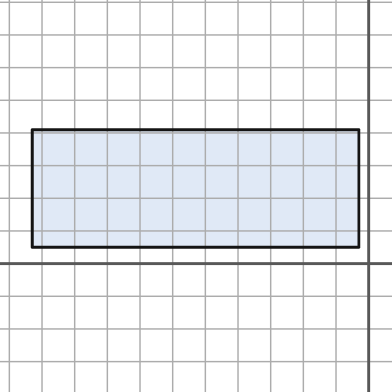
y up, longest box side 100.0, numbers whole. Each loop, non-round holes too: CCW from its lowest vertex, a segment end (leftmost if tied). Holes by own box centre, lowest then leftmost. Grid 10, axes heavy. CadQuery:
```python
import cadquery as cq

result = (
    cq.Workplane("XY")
    .moveTo(-103.0, 5.0)
    .lineTo(-3.0, 5.0)
    .lineTo(-3.0, 41.0)
    .lineTo(-103.0, 41.0)
    .close()
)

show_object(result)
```